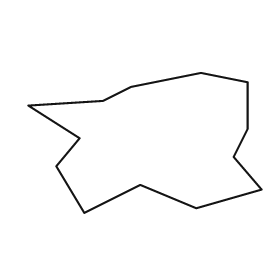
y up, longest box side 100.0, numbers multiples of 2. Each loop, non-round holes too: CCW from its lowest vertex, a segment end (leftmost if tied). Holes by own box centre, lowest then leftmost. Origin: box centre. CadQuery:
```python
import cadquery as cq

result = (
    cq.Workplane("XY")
    .moveTo(-26.0, -30.0)
    .lineTo(-2.0, -18.0)
    .lineTo(22.0, -28.0)
    .lineTo(50.0, -20.0)
    .lineTo(38.0, -6.0)
    .lineTo(44.0, 6.0)
    .lineTo(44.0, 26.0)
    .lineTo(24.0, 30.0)
    .lineTo(-6.0, 24.0)
    .lineTo(-18.0, 18.0)
    .lineTo(-50.0, 16.0)
    .lineTo(-28.0, 2.0)
    .lineTo(-38.0, -10.0)
    .close()
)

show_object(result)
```